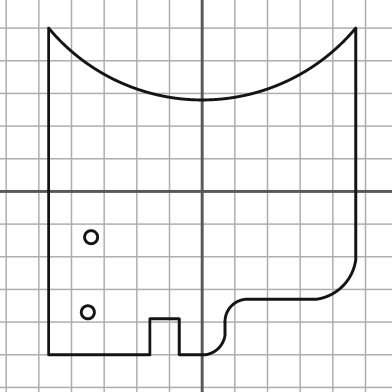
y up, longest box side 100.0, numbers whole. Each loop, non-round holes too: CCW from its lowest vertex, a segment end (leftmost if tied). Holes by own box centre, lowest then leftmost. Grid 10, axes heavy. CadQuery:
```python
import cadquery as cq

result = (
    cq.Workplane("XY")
    .moveTo(-47.0, -50.0)
    .lineTo(-16.0, -50.0)
    .lineTo(-16.0, -39.0)
    .lineTo(-7.0, -39.0)
    .lineTo(-7.0, -50.0)
    .lineTo(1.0, -50.0)
    .threePointArc((5.0, -48.0), (7.0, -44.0))
    .lineTo(7.0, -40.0)
    .threePointArc((9.0, -35.0), (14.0, -33.0))
    .lineTo(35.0, -33.0)
    .threePointArc((43.0, -29.0), (47.0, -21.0))
    .lineTo(47.0, 50.0)
    .threePointArc((0.0, 28.0), (-47.0, 50.0))
    .close()
    .moveTo(-35.0, -37.0)
    .circle(2.0)
    .moveTo(-34.0, -14.0)
    .circle(2.0)
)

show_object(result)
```